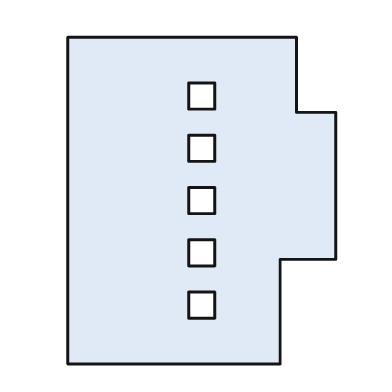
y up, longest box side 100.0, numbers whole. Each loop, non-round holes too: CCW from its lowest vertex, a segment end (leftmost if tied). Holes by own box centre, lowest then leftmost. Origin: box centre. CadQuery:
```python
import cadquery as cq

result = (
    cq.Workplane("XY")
    .moveTo(-41.0, -50.0)
    .lineTo(24.0, -50.0)
    .lineTo(24.0, -18.0)
    .lineTo(41.0, -18.0)
    .lineTo(41.0, 27.0)
    .lineTo(29.0, 27.0)
    .lineTo(29.0, 50.0)
    .lineTo(-41.0, 50.0)
    .close()
    .moveTo(-4.0, -36.0)
    .lineTo(4.0, -36.0)
    .lineTo(4.0, -28.0)
    .lineTo(-4.0, -28.0)
    .close()
    .moveTo(-4.0, -20.0)
    .lineTo(4.0, -20.0)
    .lineTo(4.0, -12.0)
    .lineTo(-4.0, -12.0)
    .close()
    .moveTo(-4.0, -4.0)
    .lineTo(4.0, -4.0)
    .lineTo(4.0, 4.0)
    .lineTo(-4.0, 4.0)
    .close()
    .moveTo(-4.0, 12.0)
    .lineTo(4.0, 12.0)
    .lineTo(4.0, 20.0)
    .lineTo(-4.0, 20.0)
    .close()
    .moveTo(-4.0, 28.0)
    .lineTo(4.0, 28.0)
    .lineTo(4.0, 36.0)
    .lineTo(-4.0, 36.0)
    .close()
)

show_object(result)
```